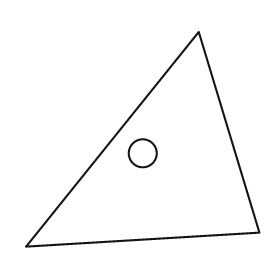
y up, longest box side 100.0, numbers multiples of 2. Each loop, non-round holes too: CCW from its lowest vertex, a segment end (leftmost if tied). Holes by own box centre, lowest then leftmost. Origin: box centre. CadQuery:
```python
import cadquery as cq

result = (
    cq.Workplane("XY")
    .moveTo(-50.0, -46.0)
    .lineTo(50.0, -40.0)
    .lineTo(24.0, 46.0)
    .close()
    .moveTo(0.0, -6.0)
    .circle(6.0)
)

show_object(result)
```